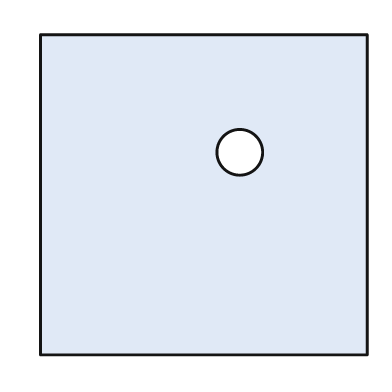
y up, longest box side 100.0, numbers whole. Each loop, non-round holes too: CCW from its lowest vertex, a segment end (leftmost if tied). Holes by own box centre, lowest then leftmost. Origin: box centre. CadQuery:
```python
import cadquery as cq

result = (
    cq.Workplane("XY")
    .moveTo(-50.0, -49.0)
    .lineTo(50.0, -49.0)
    .lineTo(50.0, 49.0)
    .lineTo(-50.0, 49.0)
    .close()
    .moveTo(11.0, 13.0)
    .circle(7.0)
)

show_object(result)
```